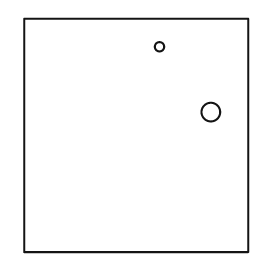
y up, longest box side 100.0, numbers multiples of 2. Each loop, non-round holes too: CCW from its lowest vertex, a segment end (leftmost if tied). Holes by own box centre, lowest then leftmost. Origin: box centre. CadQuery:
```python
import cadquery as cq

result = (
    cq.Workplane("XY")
    .moveTo(-48.0, -50.0)
    .lineTo(48.0, -50.0)
    .lineTo(48.0, 50.0)
    .lineTo(-48.0, 50.0)
    .close()
    .moveTo(32.0, 10.0)
    .circle(4.0)
    .moveTo(10.0, 38.0)
    .circle(2.0)
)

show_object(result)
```